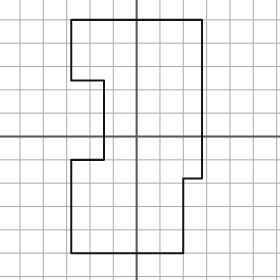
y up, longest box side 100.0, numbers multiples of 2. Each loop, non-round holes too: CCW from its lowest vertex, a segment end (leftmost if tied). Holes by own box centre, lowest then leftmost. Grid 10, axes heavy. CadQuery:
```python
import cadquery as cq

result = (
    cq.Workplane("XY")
    .moveTo(-28.0, -50.0)
    .lineTo(20.0, -50.0)
    .lineTo(20.0, -18.0)
    .lineTo(28.0, -18.0)
    .lineTo(28.0, 50.0)
    .lineTo(-28.0, 50.0)
    .lineTo(-28.0, 24.0)
    .lineTo(-14.0, 24.0)
    .lineTo(-14.0, -10.0)
    .lineTo(-28.0, -10.0)
    .close()
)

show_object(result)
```